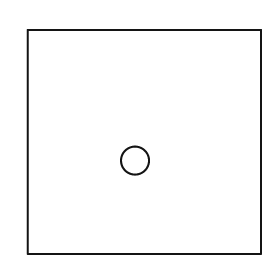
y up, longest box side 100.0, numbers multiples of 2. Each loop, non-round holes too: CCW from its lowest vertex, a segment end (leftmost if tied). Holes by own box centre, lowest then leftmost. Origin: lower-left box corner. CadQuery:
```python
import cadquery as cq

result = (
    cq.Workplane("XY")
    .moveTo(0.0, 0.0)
    .lineTo(100.0, 0.0)
    .lineTo(100.0, 96.0)
    .lineTo(0.0, 96.0)
    .close()
    .moveTo(46.0, 40.0)
    .circle(6.0)
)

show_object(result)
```